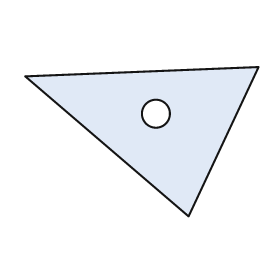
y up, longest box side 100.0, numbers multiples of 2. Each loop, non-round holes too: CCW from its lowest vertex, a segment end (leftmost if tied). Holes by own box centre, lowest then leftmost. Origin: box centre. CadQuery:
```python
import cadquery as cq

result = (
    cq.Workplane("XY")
    .moveTo(20.0, -32.0)
    .lineTo(50.0, 32.0)
    .lineTo(-50.0, 28.0)
    .close()
    .moveTo(6.0, 12.0)
    .circle(6.0)
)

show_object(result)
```